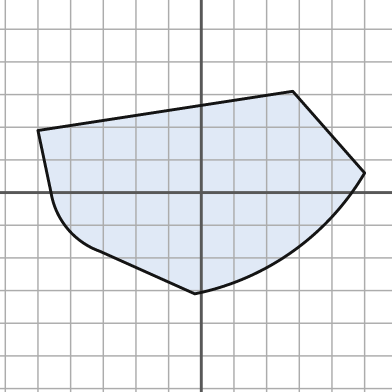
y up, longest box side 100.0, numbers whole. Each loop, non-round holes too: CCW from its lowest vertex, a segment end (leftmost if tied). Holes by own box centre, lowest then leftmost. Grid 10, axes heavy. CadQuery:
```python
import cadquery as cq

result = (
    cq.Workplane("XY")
    .moveTo(-2.0, -31.0)
    .threePointArc((28.0, -18.0), (50.0, 6.0))
    .lineTo(28.0, 31.0)
    .lineTo(-50.0, 19.0)
    .lineTo(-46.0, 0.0)
    .threePointArc((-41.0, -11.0), (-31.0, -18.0))
    .close()
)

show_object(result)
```